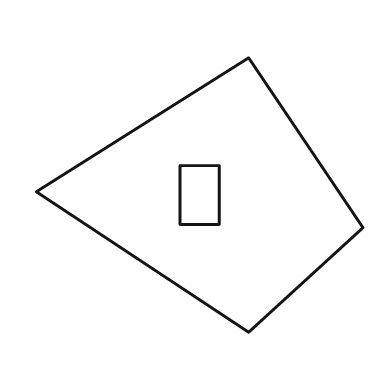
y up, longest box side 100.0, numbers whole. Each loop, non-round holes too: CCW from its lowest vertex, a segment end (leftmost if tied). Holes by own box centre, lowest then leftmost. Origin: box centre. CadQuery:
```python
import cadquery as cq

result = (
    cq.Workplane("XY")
    .moveTo(15.0, -42.0)
    .lineTo(50.0, -10.0)
    .lineTo(15.0, 42.0)
    .lineTo(-50.0, 1.0)
    .close()
    .moveTo(-6.0, -9.0)
    .lineTo(6.0, -9.0)
    .lineTo(6.0, 9.0)
    .lineTo(-6.0, 9.0)
    .close()
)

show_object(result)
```